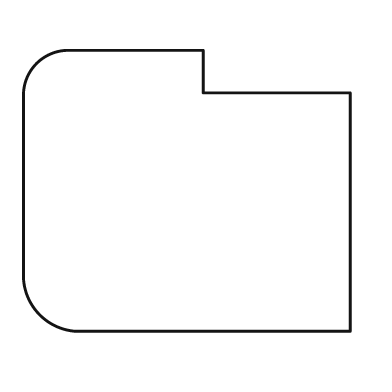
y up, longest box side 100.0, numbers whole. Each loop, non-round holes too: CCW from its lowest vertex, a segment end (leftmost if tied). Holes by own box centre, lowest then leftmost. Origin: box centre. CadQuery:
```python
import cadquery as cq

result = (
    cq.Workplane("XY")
    .moveTo(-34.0, -43.0)
    .lineTo(50.0, -43.0)
    .lineTo(50.0, 30.0)
    .lineTo(5.0, 30.0)
    .lineTo(5.0, 43.0)
    .lineTo(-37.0, 43.0)
    .threePointArc((-46.0, 39.0), (-50.0, 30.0))
    .lineTo(-50.0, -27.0)
    .threePointArc((-45.0, -38.0), (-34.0, -43.0))
    .close()
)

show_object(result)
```